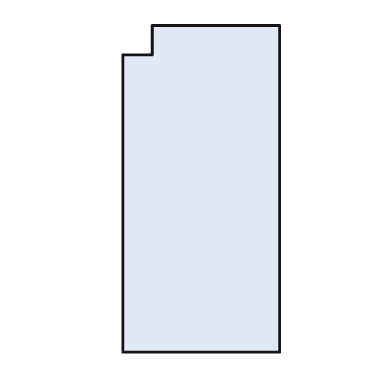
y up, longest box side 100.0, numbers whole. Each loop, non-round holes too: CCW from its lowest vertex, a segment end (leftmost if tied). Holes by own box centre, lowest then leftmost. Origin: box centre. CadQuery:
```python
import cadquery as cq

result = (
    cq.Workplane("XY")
    .moveTo(-24.0, -50.0)
    .lineTo(24.0, -50.0)
    .lineTo(24.0, 50.0)
    .lineTo(-15.0, 50.0)
    .lineTo(-15.0, 41.0)
    .lineTo(-24.0, 41.0)
    .close()
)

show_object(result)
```